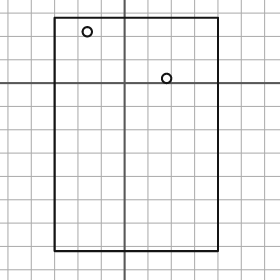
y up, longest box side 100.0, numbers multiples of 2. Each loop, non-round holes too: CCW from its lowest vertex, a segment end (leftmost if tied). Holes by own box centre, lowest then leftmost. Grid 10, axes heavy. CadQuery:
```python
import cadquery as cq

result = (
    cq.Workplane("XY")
    .moveTo(-30.0, -72.0)
    .lineTo(40.0, -72.0)
    .lineTo(40.0, 28.0)
    .lineTo(-30.0, 28.0)
    .close()
    .moveTo(18.0, 2.0)
    .circle(2.0)
    .moveTo(-16.0, 22.0)
    .circle(2.0)
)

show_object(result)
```